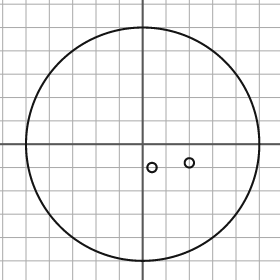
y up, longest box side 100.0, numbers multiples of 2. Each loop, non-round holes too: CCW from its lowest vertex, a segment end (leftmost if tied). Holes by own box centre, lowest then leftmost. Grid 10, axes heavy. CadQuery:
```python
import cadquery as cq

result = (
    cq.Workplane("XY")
    .moveTo(0.0, 0.0)
    .circle(50.0)
    .moveTo(4.0, -10.0)
    .circle(2.0)
    .moveTo(20.0, -8.0)
    .circle(2.0)
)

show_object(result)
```